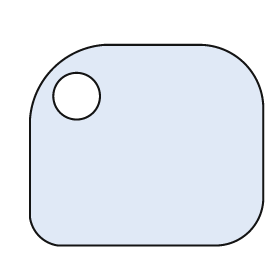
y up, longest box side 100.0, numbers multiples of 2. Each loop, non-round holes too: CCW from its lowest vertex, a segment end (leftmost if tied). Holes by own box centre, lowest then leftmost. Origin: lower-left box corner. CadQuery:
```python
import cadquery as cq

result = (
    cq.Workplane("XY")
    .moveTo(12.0, 0.0)
    .lineTo(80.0, 0.0)
    .threePointArc((94.0, 6.0), (100.0, 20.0))
    .lineTo(100.0, 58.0)
    .threePointArc((92.0, 78.0), (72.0, 86.0))
    .lineTo(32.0, 86.0)
    .threePointArc((10.0, 76.0), (0.0, 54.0))
    .lineTo(0.0, 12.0)
    .threePointArc((4.0, 4.0), (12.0, 0.0))
    .close()
    .moveTo(20.0, 64.0)
    .circle(10.0)
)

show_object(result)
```